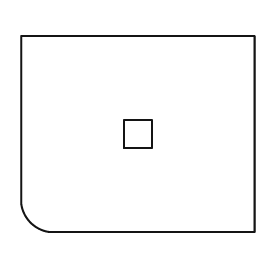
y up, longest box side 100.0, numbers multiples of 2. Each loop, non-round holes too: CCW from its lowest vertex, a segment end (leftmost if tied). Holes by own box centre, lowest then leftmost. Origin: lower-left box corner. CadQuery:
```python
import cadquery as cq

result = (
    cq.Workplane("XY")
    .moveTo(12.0, 0.0)
    .lineTo(100.0, 0.0)
    .lineTo(100.0, 84.0)
    .lineTo(0.0, 84.0)
    .lineTo(0.0, 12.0)
    .threePointArc((4.0, 4.0), (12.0, 0.0))
    .close()
    .moveTo(44.0, 36.0)
    .lineTo(56.0, 36.0)
    .lineTo(56.0, 48.0)
    .lineTo(44.0, 48.0)
    .close()
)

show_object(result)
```